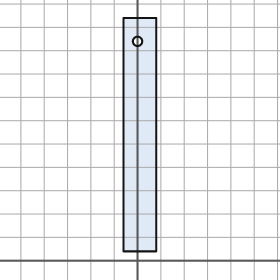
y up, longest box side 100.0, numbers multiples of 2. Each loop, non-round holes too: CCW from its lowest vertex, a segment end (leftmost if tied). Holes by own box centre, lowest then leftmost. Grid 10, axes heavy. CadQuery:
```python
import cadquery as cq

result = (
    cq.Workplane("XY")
    .moveTo(-6.0, 4.0)
    .lineTo(8.0, 4.0)
    .lineTo(8.0, 104.0)
    .lineTo(-6.0, 104.0)
    .close()
    .moveTo(0.0, 94.0)
    .circle(2.0)
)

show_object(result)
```